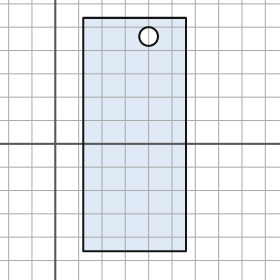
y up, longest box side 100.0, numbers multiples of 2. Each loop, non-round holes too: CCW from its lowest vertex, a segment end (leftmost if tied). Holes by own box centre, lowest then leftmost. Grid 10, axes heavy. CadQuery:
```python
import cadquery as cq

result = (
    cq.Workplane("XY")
    .moveTo(12.0, -46.0)
    .lineTo(56.0, -46.0)
    .lineTo(56.0, 54.0)
    .lineTo(12.0, 54.0)
    .close()
    .moveTo(40.0, 46.0)
    .circle(4.0)
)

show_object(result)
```